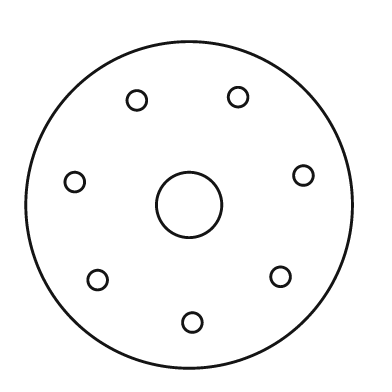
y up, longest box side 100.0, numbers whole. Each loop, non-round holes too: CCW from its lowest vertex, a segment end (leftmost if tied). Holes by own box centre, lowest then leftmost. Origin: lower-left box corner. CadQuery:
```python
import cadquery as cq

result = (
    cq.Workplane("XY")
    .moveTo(50.0, 50.0)
    .circle(50.0)
    .moveTo(51.0, 14.0)
    .circle(3.0)
    .moveTo(22.0, 27.0)
    .circle(3.0)
    .moveTo(78.0, 28.0)
    .circle(3.0)
    .moveTo(50.0, 50.0)
    .circle(10.0)
    .moveTo(15.0, 57.0)
    .circle(3.0)
    .moveTo(85.0, 59.0)
    .circle(3.0)
    .moveTo(34.0, 82.0)
    .circle(3.0)
    .moveTo(65.0, 83.0)
    .circle(3.0)
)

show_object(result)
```